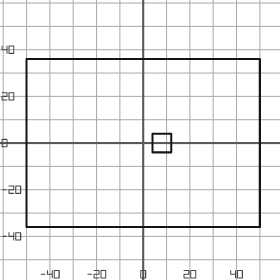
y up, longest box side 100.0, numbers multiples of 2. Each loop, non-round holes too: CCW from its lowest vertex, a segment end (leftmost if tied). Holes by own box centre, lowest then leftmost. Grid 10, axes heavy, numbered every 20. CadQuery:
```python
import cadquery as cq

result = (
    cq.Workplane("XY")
    .moveTo(-50.0, -36.0)
    .lineTo(50.0, -36.0)
    .lineTo(50.0, 36.0)
    .lineTo(-50.0, 36.0)
    .close()
    .moveTo(4.0, -4.0)
    .lineTo(12.0, -4.0)
    .lineTo(12.0, 4.0)
    .lineTo(4.0, 4.0)
    .close()
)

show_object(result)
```